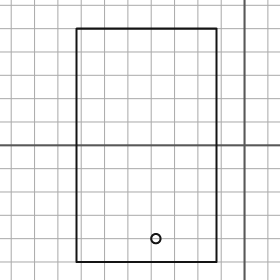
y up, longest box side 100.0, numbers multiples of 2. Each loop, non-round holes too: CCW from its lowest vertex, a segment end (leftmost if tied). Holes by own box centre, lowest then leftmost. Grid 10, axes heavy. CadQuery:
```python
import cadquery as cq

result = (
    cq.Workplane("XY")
    .moveTo(-72.0, -50.0)
    .lineTo(-12.0, -50.0)
    .lineTo(-12.0, 50.0)
    .lineTo(-72.0, 50.0)
    .close()
    .moveTo(-38.0, -40.0)
    .circle(2.0)
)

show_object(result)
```